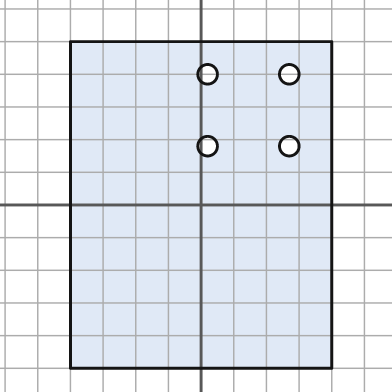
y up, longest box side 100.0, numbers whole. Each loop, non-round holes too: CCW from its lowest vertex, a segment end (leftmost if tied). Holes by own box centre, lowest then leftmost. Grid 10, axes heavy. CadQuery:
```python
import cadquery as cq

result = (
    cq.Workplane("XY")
    .moveTo(-40.0, -50.0)
    .lineTo(40.0, -50.0)
    .lineTo(40.0, 50.0)
    .lineTo(-40.0, 50.0)
    .close()
    .moveTo(2.0, 18.0)
    .circle(3.0)
    .moveTo(27.0, 18.0)
    .circle(3.0)
    .moveTo(2.0, 40.0)
    .circle(3.0)
    .moveTo(27.0, 40.0)
    .circle(3.0)
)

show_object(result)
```